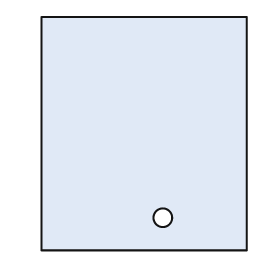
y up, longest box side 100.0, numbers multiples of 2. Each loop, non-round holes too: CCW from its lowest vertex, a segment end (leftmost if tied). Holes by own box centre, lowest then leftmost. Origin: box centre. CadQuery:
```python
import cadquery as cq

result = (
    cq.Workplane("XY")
    .moveTo(-44.0, -50.0)
    .lineTo(44.0, -50.0)
    .lineTo(44.0, 50.0)
    .lineTo(-44.0, 50.0)
    .close()
    .moveTo(8.0, -36.0)
    .circle(4.0)
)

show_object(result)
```